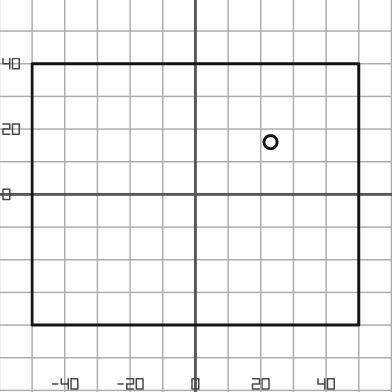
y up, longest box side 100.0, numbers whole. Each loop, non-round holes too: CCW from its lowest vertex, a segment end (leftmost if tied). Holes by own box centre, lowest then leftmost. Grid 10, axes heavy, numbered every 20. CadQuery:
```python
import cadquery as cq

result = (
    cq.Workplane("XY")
    .moveTo(-50.0, -40.0)
    .lineTo(50.0, -40.0)
    .lineTo(50.0, 40.0)
    .lineTo(-50.0, 40.0)
    .close()
    .moveTo(23.0, 16.0)
    .circle(2.0)
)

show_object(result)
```